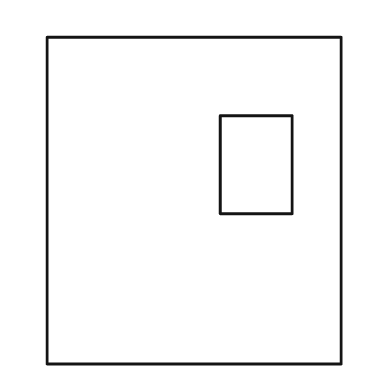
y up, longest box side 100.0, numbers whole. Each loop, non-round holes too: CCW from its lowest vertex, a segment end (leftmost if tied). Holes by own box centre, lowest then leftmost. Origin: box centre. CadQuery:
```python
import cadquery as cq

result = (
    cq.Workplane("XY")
    .moveTo(-45.0, -50.0)
    .lineTo(45.0, -50.0)
    .lineTo(45.0, 50.0)
    .lineTo(-45.0, 50.0)
    .close()
    .moveTo(8.0, -4.0)
    .lineTo(30.0, -4.0)
    .lineTo(30.0, 26.0)
    .lineTo(8.0, 26.0)
    .close()
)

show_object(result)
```